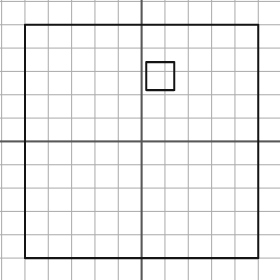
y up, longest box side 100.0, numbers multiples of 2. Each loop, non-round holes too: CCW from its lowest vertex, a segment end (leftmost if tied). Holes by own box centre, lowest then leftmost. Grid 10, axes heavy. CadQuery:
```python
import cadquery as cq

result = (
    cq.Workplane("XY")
    .moveTo(-50.0, -50.0)
    .lineTo(50.0, -50.0)
    .lineTo(50.0, 50.0)
    .lineTo(-50.0, 50.0)
    .close()
    .moveTo(2.0, 22.0)
    .lineTo(14.0, 22.0)
    .lineTo(14.0, 34.0)
    .lineTo(2.0, 34.0)
    .close()
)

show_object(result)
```